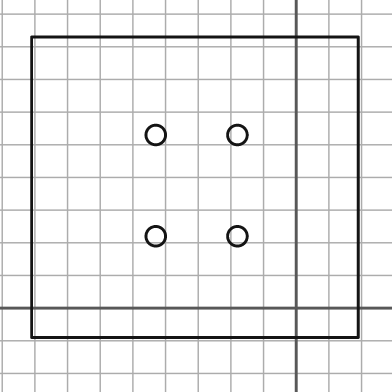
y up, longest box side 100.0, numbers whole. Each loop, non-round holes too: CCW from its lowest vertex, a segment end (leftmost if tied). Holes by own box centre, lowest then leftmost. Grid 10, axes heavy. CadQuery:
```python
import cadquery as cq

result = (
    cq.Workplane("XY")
    .moveTo(-81.0, -9.0)
    .lineTo(19.0, -9.0)
    .lineTo(19.0, 83.0)
    .lineTo(-81.0, 83.0)
    .close()
    .moveTo(-43.0, 22.0)
    .circle(3.0)
    .moveTo(-18.0, 22.0)
    .circle(3.0)
    .moveTo(-43.0, 53.0)
    .circle(3.0)
    .moveTo(-18.0, 53.0)
    .circle(3.0)
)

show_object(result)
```